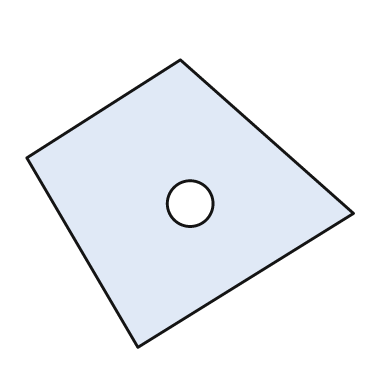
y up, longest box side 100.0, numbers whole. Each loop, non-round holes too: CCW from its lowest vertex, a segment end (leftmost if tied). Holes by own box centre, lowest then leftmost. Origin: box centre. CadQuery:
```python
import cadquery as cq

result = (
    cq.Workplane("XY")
    .moveTo(-16.0, -44.0)
    .lineTo(50.0, -3.0)
    .lineTo(-3.0, 44.0)
    .lineTo(-50.0, 14.0)
    .close()
    .moveTo(0.0, 0.0)
    .circle(7.0)
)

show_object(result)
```